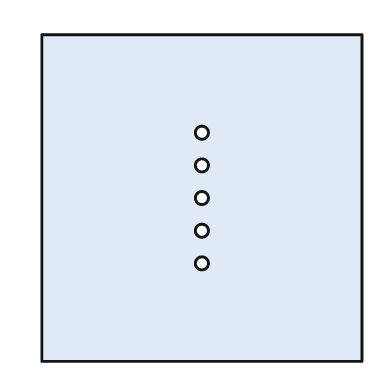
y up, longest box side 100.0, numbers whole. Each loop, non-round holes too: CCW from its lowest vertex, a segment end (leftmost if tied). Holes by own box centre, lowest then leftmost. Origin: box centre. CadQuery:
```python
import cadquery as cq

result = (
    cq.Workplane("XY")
    .moveTo(-49.0, -50.0)
    .lineTo(49.0, -50.0)
    .lineTo(49.0, 50.0)
    .lineTo(-49.0, 50.0)
    .close()
    .moveTo(0.0, -20.0)
    .circle(2.0)
    .moveTo(0.0, -10.0)
    .circle(2.0)
    .moveTo(0.0, 0.0)
    .circle(2.0)
    .moveTo(0.0, 10.0)
    .circle(2.0)
    .moveTo(0.0, 20.0)
    .circle(2.0)
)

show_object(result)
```